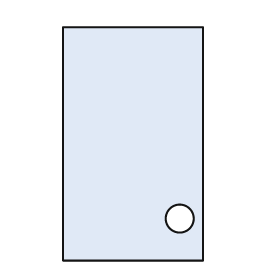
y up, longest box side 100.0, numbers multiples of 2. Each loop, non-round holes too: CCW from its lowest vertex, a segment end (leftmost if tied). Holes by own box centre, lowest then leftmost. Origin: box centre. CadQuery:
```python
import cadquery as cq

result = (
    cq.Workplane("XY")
    .moveTo(-30.0, -50.0)
    .lineTo(30.0, -50.0)
    .lineTo(30.0, 50.0)
    .lineTo(-30.0, 50.0)
    .close()
    .moveTo(20.0, -32.0)
    .circle(6.0)
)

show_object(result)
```